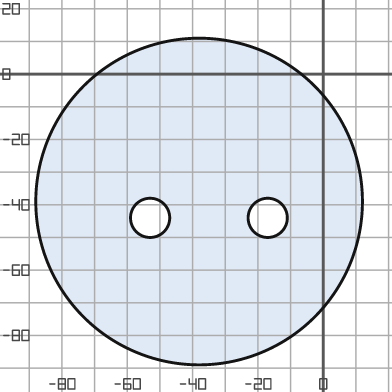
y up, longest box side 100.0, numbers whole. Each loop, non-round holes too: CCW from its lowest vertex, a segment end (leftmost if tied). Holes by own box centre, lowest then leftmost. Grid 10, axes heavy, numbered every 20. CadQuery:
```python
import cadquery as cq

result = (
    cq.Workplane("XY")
    .moveTo(-38.0, -39.0)
    .circle(50.0)
    .moveTo(-53.0, -44.0)
    .circle(6.0)
    .moveTo(-17.0, -44.0)
    .circle(6.0)
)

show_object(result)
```